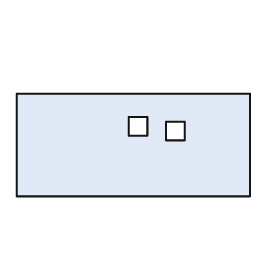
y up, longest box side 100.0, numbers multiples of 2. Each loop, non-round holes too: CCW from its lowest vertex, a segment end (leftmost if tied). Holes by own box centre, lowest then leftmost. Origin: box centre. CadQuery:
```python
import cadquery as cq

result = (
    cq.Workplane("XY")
    .moveTo(-50.0, -22.0)
    .lineTo(50.0, -22.0)
    .lineTo(50.0, 22.0)
    .lineTo(-50.0, 22.0)
    .close()
    .moveTo(14.0, 2.0)
    .lineTo(22.0, 2.0)
    .lineTo(22.0, 10.0)
    .lineTo(14.0, 10.0)
    .close()
    .moveTo(-2.0, 4.0)
    .lineTo(6.0, 4.0)
    .lineTo(6.0, 12.0)
    .lineTo(-2.0, 12.0)
    .close()
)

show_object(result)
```